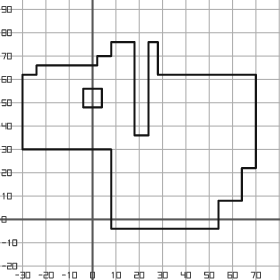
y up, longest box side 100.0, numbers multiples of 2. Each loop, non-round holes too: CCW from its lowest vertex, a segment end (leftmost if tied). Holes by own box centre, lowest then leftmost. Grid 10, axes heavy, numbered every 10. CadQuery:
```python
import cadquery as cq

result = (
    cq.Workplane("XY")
    .moveTo(8.0, -4.0)
    .lineTo(54.0, -4.0)
    .lineTo(54.0, 8.0)
    .lineTo(64.0, 8.0)
    .lineTo(64.0, 22.0)
    .lineTo(70.0, 22.0)
    .lineTo(70.0, 62.0)
    .lineTo(28.0, 62.0)
    .lineTo(28.0, 76.0)
    .lineTo(24.0, 76.0)
    .lineTo(24.0, 36.0)
    .lineTo(18.0, 36.0)
    .lineTo(18.0, 76.0)
    .lineTo(8.0, 76.0)
    .lineTo(8.0, 70.0)
    .lineTo(2.0, 70.0)
    .lineTo(2.0, 66.0)
    .lineTo(-24.0, 66.0)
    .lineTo(-24.0, 62.0)
    .lineTo(-30.0, 62.0)
    .lineTo(-30.0, 30.0)
    .lineTo(8.0, 30.0)
    .close()
    .moveTo(-4.0, 48.0)
    .lineTo(4.0, 48.0)
    .lineTo(4.0, 56.0)
    .lineTo(-4.0, 56.0)
    .close()
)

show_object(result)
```